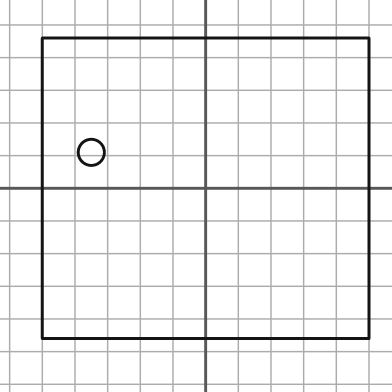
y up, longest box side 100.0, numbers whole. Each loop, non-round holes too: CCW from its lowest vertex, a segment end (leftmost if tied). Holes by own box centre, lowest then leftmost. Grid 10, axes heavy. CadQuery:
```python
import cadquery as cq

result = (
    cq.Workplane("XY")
    .moveTo(-50.0, -46.0)
    .lineTo(50.0, -46.0)
    .lineTo(50.0, 46.0)
    .lineTo(-50.0, 46.0)
    .close()
    .moveTo(-35.0, 11.0)
    .circle(4.0)
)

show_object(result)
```